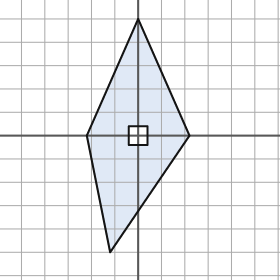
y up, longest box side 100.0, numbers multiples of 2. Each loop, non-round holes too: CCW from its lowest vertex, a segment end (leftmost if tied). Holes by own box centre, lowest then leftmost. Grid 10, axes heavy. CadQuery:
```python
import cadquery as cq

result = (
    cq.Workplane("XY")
    .moveTo(-12.0, -50.0)
    .lineTo(22.0, 0.0)
    .lineTo(0.0, 50.0)
    .lineTo(-22.0, 0.0)
    .close()
    .moveTo(-4.0, -4.0)
    .lineTo(4.0, -4.0)
    .lineTo(4.0, 4.0)
    .lineTo(-4.0, 4.0)
    .close()
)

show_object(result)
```